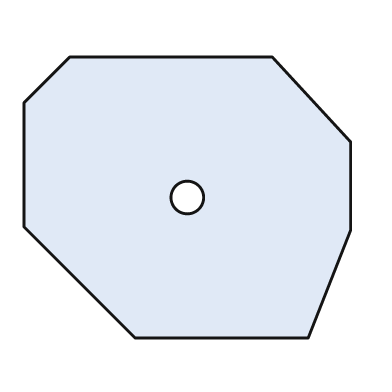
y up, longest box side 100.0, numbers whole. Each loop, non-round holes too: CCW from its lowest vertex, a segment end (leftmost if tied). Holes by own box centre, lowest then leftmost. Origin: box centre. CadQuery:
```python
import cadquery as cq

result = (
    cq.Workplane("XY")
    .moveTo(-16.0, -43.0)
    .lineTo(37.0, -43.0)
    .lineTo(50.0, -10.0)
    .lineTo(50.0, 17.0)
    .lineTo(26.0, 43.0)
    .lineTo(-36.0, 43.0)
    .lineTo(-50.0, 29.0)
    .lineTo(-50.0, -9.0)
    .close()
    .moveTo(0.0, 0.0)
    .circle(5.0)
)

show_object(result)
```